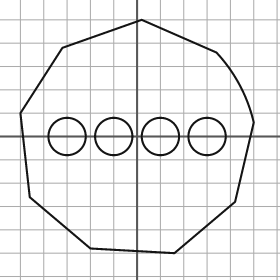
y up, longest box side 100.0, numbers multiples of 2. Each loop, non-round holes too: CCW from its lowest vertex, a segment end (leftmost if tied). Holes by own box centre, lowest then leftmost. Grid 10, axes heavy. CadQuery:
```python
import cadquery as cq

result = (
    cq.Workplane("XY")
    .moveTo(16.0, -50.0)
    .lineTo(42.0, -28.0)
    .lineTo(50.0, 6.0)
    .threePointArc((44.0, 22.0), (34.0, 36.0))
    .lineTo(2.0, 50.0)
    .lineTo(-32.0, 38.0)
    .lineTo(-50.0, 10.0)
    .lineTo(-46.0, -26.0)
    .lineTo(-20.0, -48.0)
    .close()
    .moveTo(-30.0, 0.0)
    .circle(8.0)
    .moveTo(-10.0, 0.0)
    .circle(8.0)
    .moveTo(10.0, 0.0)
    .circle(8.0)
    .moveTo(30.0, 0.0)
    .circle(8.0)
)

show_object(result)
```